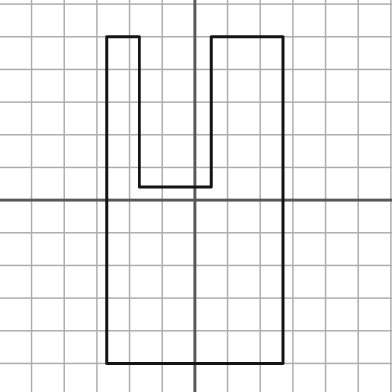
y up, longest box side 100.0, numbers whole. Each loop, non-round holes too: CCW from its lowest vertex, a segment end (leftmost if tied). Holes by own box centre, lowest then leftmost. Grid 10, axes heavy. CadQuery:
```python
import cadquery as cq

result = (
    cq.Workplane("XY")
    .moveTo(-27.0, -50.0)
    .lineTo(27.0, -50.0)
    .lineTo(27.0, 50.0)
    .lineTo(5.0, 50.0)
    .lineTo(5.0, 4.0)
    .lineTo(-17.0, 4.0)
    .lineTo(-17.0, 50.0)
    .lineTo(-27.0, 50.0)
    .close()
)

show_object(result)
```